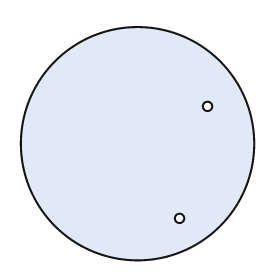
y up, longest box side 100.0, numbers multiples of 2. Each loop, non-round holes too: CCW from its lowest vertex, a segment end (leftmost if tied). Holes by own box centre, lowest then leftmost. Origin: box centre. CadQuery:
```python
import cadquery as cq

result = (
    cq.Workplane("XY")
    .moveTo(0.0, 0.0)
    .circle(50.0)
    .moveTo(18.0, -32.0)
    .circle(2.0)
    .moveTo(30.0, 16.0)
    .circle(2.0)
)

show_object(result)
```